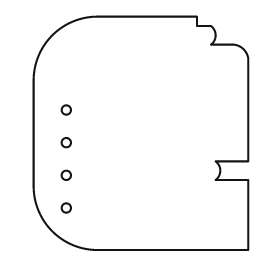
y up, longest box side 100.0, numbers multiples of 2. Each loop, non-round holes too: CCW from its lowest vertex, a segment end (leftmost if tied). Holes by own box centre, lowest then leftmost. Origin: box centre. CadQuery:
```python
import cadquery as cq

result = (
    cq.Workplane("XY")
    .moveTo(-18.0, -50.0)
    .lineTo(46.0, -50.0)
    .lineTo(46.0, -20.0)
    .lineTo(32.0, -20.0)
    .threePointArc((34.0, -16.0), (32.0, -12.0))
    .lineTo(46.0, -12.0)
    .lineTo(46.0, 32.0)
    .threePointArc((44.0, 36.0), (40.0, 38.0))
    .lineTo(30.0, 38.0)
    .threePointArc((32.0, 42.0), (30.0, 46.0))
    .lineTo(24.0, 46.0)
    .lineTo(24.0, 50.0)
    .lineTo(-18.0, 50.0)
    .threePointArc((-38.0, 42.0), (-46.0, 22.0))
    .lineTo(-46.0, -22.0)
    .threePointArc((-38.0, -42.0), (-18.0, -50.0))
    .close()
    .moveTo(-32.0, -32.0)
    .circle(2.0)
    .moveTo(-32.0, -18.0)
    .circle(2.0)
    .moveTo(-32.0, -4.0)
    .circle(2.0)
    .moveTo(-32.0, 10.0)
    .circle(2.0)
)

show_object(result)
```